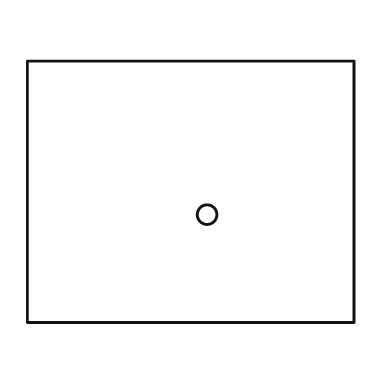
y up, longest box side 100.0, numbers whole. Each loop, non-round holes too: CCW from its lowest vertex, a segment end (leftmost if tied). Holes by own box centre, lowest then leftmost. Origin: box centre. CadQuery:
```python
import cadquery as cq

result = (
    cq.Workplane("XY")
    .moveTo(-50.0, -40.0)
    .lineTo(50.0, -40.0)
    .lineTo(50.0, 40.0)
    .lineTo(-50.0, 40.0)
    .close()
    .moveTo(5.0, -7.0)
    .circle(3.0)
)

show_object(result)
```